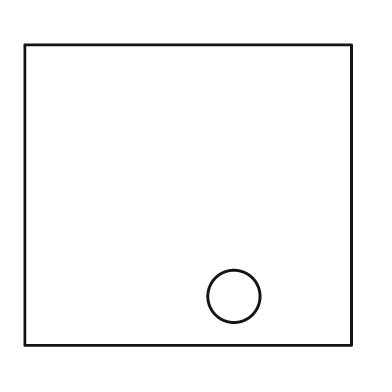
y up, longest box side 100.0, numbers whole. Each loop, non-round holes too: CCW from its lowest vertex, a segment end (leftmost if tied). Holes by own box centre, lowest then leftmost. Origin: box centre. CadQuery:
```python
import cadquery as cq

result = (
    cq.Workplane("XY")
    .moveTo(-50.0, -46.0)
    .lineTo(50.0, -46.0)
    .lineTo(50.0, 46.0)
    .lineTo(-50.0, 46.0)
    .close()
    .moveTo(14.0, -31.0)
    .circle(8.0)
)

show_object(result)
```